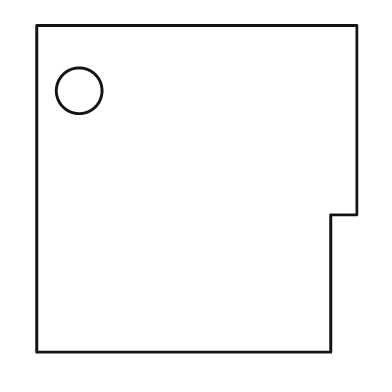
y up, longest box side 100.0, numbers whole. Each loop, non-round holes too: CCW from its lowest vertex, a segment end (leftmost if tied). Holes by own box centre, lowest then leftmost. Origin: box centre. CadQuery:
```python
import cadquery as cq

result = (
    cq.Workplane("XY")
    .moveTo(-49.0, -50.0)
    .lineTo(41.0, -50.0)
    .lineTo(41.0, -8.0)
    .lineTo(49.0, -8.0)
    .lineTo(49.0, 50.0)
    .lineTo(-49.0, 50.0)
    .close()
    .moveTo(-36.0, 30.0)
    .circle(7.0)
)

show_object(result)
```